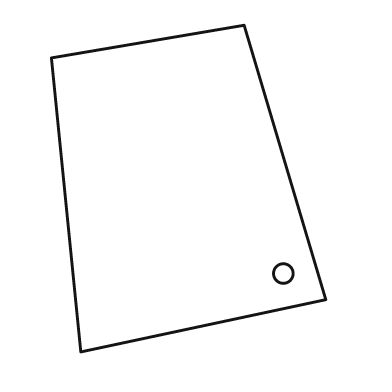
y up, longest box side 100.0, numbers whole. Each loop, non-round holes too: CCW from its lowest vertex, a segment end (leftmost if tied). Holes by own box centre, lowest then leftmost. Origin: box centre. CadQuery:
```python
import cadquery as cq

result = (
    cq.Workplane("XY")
    .moveTo(-33.0, -50.0)
    .lineTo(42.0, -34.0)
    .lineTo(17.0, 50.0)
    .lineTo(-42.0, 40.0)
    .close()
    .moveTo(29.0, -26.0)
    .circle(3.0)
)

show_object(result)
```